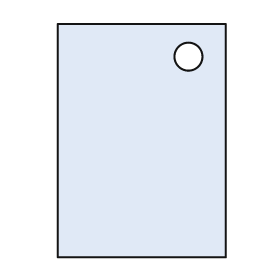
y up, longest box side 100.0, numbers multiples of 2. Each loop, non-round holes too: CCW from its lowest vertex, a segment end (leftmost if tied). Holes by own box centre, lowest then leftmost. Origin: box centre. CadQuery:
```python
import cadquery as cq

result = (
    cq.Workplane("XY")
    .moveTo(-36.0, -50.0)
    .lineTo(36.0, -50.0)
    .lineTo(36.0, 50.0)
    .lineTo(-36.0, 50.0)
    .close()
    .moveTo(20.0, 36.0)
    .circle(6.0)
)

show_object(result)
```